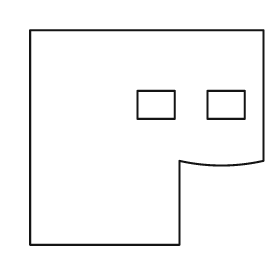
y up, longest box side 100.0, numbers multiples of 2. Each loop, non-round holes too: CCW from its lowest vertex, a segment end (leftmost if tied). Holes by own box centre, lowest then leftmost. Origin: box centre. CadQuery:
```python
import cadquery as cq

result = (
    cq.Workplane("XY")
    .moveTo(-50.0, -46.0)
    .lineTo(14.0, -46.0)
    .lineTo(14.0, -10.0)
    .threePointArc((32.0, -12.0), (50.0, -10.0))
    .lineTo(50.0, 46.0)
    .lineTo(-50.0, 46.0)
    .close()
    .moveTo(-4.0, 8.0)
    .lineTo(12.0, 8.0)
    .lineTo(12.0, 20.0)
    .lineTo(-4.0, 20.0)
    .close()
    .moveTo(26.0, 8.0)
    .lineTo(42.0, 8.0)
    .lineTo(42.0, 20.0)
    .lineTo(26.0, 20.0)
    .close()
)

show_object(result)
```